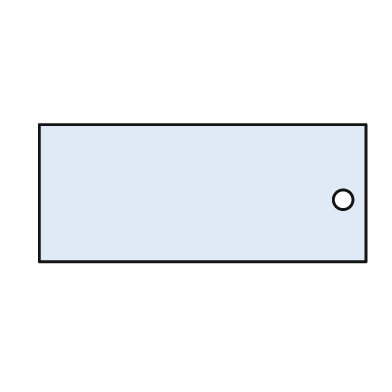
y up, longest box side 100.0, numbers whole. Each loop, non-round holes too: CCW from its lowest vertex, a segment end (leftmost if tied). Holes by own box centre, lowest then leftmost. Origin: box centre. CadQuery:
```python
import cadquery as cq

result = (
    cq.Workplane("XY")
    .moveTo(-50.0, -21.0)
    .lineTo(50.0, -21.0)
    .lineTo(50.0, 21.0)
    .lineTo(-50.0, 21.0)
    .close()
    .moveTo(43.0, -2.0)
    .circle(3.0)
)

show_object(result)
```